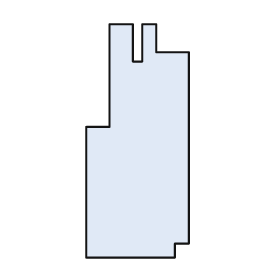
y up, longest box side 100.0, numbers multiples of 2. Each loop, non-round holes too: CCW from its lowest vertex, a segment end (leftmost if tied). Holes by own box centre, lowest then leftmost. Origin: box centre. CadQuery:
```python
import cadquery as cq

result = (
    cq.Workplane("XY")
    .moveTo(-22.0, -50.0)
    .lineTo(16.0, -50.0)
    .lineTo(16.0, -44.0)
    .lineTo(22.0, -44.0)
    .lineTo(22.0, 38.0)
    .lineTo(8.0, 38.0)
    .lineTo(8.0, 50.0)
    .lineTo(2.0, 50.0)
    .lineTo(2.0, 34.0)
    .lineTo(-2.0, 34.0)
    .lineTo(-2.0, 50.0)
    .lineTo(-12.0, 50.0)
    .lineTo(-12.0, 6.0)
    .lineTo(-22.0, 6.0)
    .close()
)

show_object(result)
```